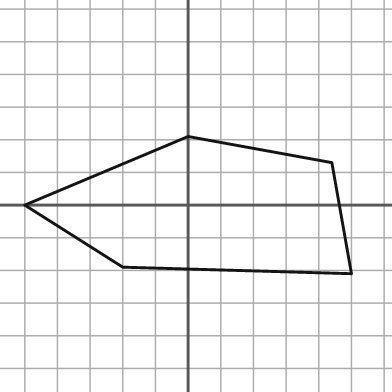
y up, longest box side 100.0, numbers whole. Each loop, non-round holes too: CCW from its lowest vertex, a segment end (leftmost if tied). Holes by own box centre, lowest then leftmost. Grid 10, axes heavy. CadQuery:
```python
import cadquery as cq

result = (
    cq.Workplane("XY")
    .moveTo(50.0, -21.0)
    .lineTo(44.0, 13.0)
    .lineTo(0.0, 21.0)
    .lineTo(-50.0, 0.0)
    .lineTo(-20.0, -19.0)
    .close()
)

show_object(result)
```